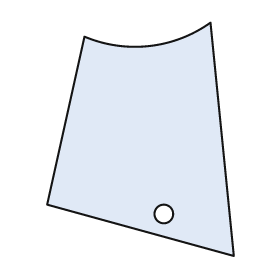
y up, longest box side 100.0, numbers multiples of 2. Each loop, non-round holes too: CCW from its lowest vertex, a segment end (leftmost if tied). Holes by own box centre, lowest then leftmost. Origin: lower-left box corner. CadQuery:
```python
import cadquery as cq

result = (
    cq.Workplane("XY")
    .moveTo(80.0, 0.0)
    .lineTo(70.0, 100.0)
    .threePointArc((44.0, 90.0), (16.0, 94.0))
    .lineTo(0.0, 22.0)
    .close()
    .moveTo(50.0, 18.0)
    .circle(4.0)
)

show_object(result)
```